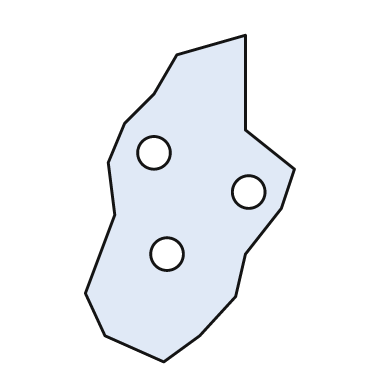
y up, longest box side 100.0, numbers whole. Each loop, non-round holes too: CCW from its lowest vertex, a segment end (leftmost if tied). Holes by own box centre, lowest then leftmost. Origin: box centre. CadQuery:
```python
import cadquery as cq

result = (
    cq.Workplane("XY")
    .moveTo(-8.0, -50.0)
    .lineTo(3.0, -42.0)
    .lineTo(14.0, -30.0)
    .lineTo(17.0, -17.0)
    .lineTo(28.0, -3.0)
    .lineTo(32.0, 9.0)
    .lineTo(17.0, 21.0)
    .lineTo(17.0, 50.0)
    .lineTo(-4.0, 44.0)
    .lineTo(-11.0, 32.0)
    .lineTo(-20.0, 23.0)
    .lineTo(-25.0, 11.0)
    .lineTo(-23.0, -5.0)
    .lineTo(-32.0, -29.0)
    .lineTo(-26.0, -42.0)
    .close()
    .moveTo(-7.0, -17.0)
    .circle(5.0)
    .moveTo(18.0, 2.0)
    .circle(5.0)
    .moveTo(-11.0, 14.0)
    .circle(5.0)
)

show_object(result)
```